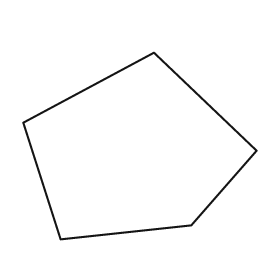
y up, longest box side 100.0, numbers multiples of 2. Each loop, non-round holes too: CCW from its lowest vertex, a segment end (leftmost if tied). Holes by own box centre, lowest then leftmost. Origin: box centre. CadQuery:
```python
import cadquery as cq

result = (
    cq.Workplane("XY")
    .moveTo(-34.0, -40.0)
    .lineTo(22.0, -34.0)
    .lineTo(50.0, -2.0)
    .lineTo(6.0, 40.0)
    .lineTo(-50.0, 10.0)
    .close()
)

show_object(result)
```